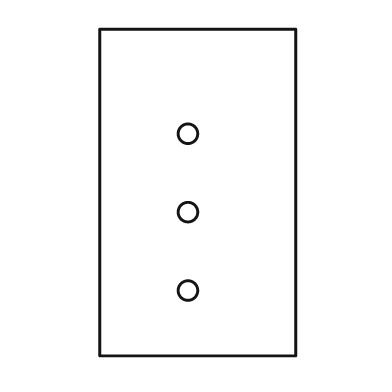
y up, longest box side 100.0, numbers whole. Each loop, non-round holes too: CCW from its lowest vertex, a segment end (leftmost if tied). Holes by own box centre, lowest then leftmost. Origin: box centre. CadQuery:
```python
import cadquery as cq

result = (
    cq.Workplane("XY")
    .moveTo(-30.0, -50.0)
    .lineTo(30.0, -50.0)
    .lineTo(30.0, 50.0)
    .lineTo(-30.0, 50.0)
    .close()
    .moveTo(-3.0, -30.0)
    .circle(3.0)
    .moveTo(-3.0, -6.0)
    .circle(3.0)
    .moveTo(-3.0, 18.0)
    .circle(3.0)
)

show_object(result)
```